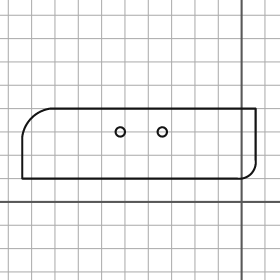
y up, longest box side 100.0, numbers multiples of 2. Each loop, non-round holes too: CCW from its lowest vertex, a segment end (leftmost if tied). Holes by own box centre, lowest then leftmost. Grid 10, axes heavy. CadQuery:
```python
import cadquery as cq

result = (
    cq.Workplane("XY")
    .moveTo(-94.0, 10.0)
    .lineTo(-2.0, 10.0)
    .threePointArc((4.0, 12.0), (6.0, 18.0))
    .lineTo(6.0, 40.0)
    .lineTo(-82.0, 40.0)
    .threePointArc((-90.0, 36.0), (-94.0, 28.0))
    .close()
    .moveTo(-52.0, 30.0)
    .circle(2.0)
    .moveTo(-34.0, 30.0)
    .circle(2.0)
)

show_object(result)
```